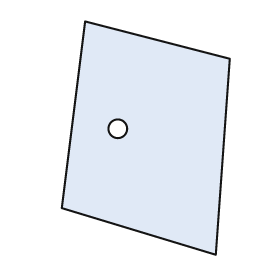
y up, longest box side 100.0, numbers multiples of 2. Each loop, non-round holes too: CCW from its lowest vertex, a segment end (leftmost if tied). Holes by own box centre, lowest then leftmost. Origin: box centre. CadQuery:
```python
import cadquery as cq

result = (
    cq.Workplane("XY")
    .moveTo(30.0, -50.0)
    .lineTo(36.0, 34.0)
    .lineTo(-26.0, 50.0)
    .lineTo(-36.0, -30.0)
    .close()
    .moveTo(-12.0, 4.0)
    .circle(4.0)
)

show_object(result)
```